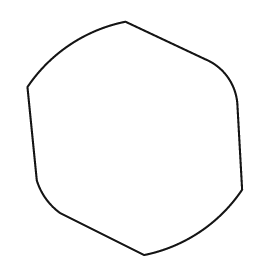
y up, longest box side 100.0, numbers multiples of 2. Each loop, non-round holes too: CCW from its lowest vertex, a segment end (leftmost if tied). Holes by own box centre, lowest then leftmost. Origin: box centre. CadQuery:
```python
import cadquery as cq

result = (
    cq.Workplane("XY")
    .moveTo(4.0, -50.0)
    .threePointArc((28.0, -40.0), (46.0, -22.0))
    .lineTo(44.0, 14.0)
    .threePointArc((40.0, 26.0), (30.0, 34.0))
    .lineTo(-4.0, 50.0)
    .threePointArc((-28.0, 40.0), (-46.0, 22.0))
    .lineTo(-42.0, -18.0)
    .threePointArc((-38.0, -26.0), (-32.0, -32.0))
    .close()
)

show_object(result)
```